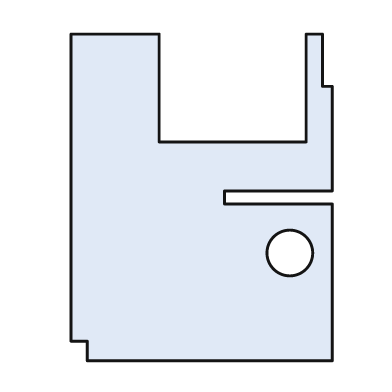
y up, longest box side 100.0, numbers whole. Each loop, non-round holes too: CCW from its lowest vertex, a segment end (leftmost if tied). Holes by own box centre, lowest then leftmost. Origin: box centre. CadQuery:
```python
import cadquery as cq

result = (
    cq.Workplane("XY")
    .moveTo(-35.0, -50.0)
    .lineTo(40.0, -50.0)
    .lineTo(40.0, -2.0)
    .lineTo(7.0, -2.0)
    .lineTo(7.0, 2.0)
    .lineTo(40.0, 2.0)
    .lineTo(40.0, 34.0)
    .lineTo(37.0, 34.0)
    .lineTo(37.0, 50.0)
    .lineTo(32.0, 50.0)
    .lineTo(32.0, 17.0)
    .lineTo(-13.0, 17.0)
    .lineTo(-13.0, 50.0)
    .lineTo(-40.0, 50.0)
    .lineTo(-40.0, -44.0)
    .lineTo(-35.0, -44.0)
    .close()
    .moveTo(27.0, -17.0)
    .circle(7.0)
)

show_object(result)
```